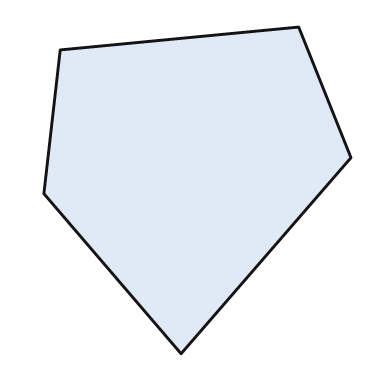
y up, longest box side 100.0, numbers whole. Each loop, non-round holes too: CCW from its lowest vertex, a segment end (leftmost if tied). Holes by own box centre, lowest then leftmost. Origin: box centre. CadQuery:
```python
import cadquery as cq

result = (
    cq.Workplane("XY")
    .moveTo(-5.0, -50.0)
    .lineTo(47.0, 10.0)
    .lineTo(31.0, 50.0)
    .lineTo(-42.0, 43.0)
    .lineTo(-47.0, -1.0)
    .close()
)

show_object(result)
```